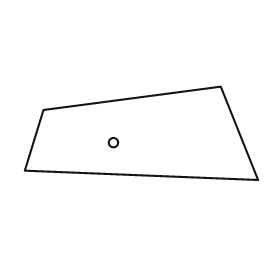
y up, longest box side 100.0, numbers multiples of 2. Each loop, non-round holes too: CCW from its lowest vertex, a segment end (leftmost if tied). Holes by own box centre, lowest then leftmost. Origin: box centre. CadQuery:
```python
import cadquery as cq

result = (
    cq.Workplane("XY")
    .moveTo(50.0, -20.0)
    .lineTo(34.0, 20.0)
    .lineTo(-42.0, 10.0)
    .lineTo(-50.0, -16.0)
    .close()
    .moveTo(-12.0, -4.0)
    .circle(2.0)
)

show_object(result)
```